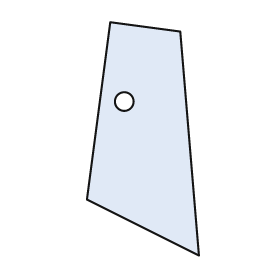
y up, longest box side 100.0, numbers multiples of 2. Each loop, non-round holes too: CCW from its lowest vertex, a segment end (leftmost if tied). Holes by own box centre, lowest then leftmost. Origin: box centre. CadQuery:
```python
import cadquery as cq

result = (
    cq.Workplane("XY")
    .moveTo(24.0, -50.0)
    .lineTo(16.0, 46.0)
    .lineTo(-14.0, 50.0)
    .lineTo(-24.0, -26.0)
    .close()
    .moveTo(-8.0, 16.0)
    .circle(4.0)
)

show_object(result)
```